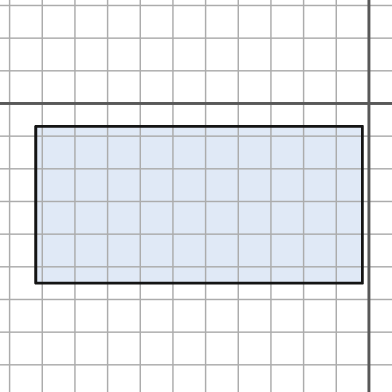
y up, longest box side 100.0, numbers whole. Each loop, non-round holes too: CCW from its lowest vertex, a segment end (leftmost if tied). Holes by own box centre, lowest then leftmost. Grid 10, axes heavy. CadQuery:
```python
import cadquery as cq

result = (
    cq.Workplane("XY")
    .moveTo(-102.0, -55.0)
    .lineTo(-2.0, -55.0)
    .lineTo(-2.0, -7.0)
    .lineTo(-102.0, -7.0)
    .close()
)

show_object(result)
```